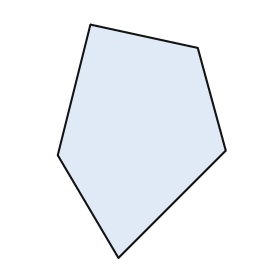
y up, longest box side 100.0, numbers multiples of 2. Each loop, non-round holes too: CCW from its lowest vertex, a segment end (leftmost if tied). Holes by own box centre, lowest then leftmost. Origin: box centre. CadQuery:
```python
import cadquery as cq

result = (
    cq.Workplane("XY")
    .moveTo(-10.0, -50.0)
    .lineTo(36.0, -4.0)
    .lineTo(24.0, 40.0)
    .lineTo(-22.0, 50.0)
    .lineTo(-36.0, -6.0)
    .close()
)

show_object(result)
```